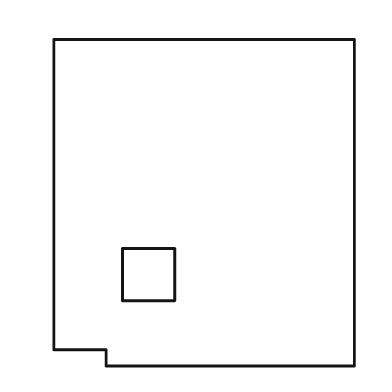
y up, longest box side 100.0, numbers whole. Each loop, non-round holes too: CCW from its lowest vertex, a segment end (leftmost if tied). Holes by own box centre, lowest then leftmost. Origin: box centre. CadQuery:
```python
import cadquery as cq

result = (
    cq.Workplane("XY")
    .moveTo(-30.0, -50.0)
    .lineTo(46.0, -50.0)
    .lineTo(46.0, 50.0)
    .lineTo(-46.0, 50.0)
    .lineTo(-46.0, -45.0)
    .lineTo(-30.0, -45.0)
    .close()
    .moveTo(-25.0, -30.0)
    .lineTo(-9.0, -30.0)
    .lineTo(-9.0, -14.0)
    .lineTo(-25.0, -14.0)
    .close()
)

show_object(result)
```